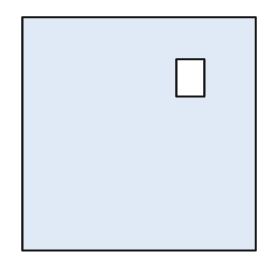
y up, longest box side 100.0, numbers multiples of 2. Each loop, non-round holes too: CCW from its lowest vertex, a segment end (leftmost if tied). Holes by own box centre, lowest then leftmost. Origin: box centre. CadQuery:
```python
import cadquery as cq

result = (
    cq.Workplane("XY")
    .moveTo(-50.0, -50.0)
    .lineTo(50.0, -50.0)
    .lineTo(50.0, 50.0)
    .lineTo(-50.0, 50.0)
    .close()
    .moveTo(16.0, 16.0)
    .lineTo(28.0, 16.0)
    .lineTo(28.0, 32.0)
    .lineTo(16.0, 32.0)
    .close()
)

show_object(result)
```